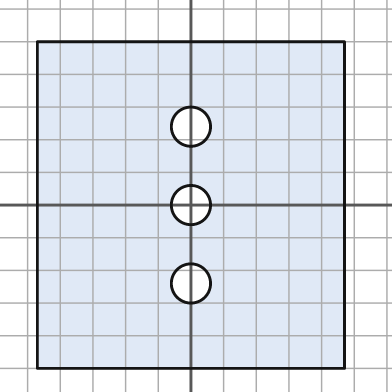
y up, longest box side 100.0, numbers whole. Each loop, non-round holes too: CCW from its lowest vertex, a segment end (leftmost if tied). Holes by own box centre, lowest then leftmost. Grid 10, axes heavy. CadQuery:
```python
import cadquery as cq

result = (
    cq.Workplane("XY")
    .moveTo(-47.0, -50.0)
    .lineTo(47.0, -50.0)
    .lineTo(47.0, 50.0)
    .lineTo(-47.0, 50.0)
    .close()
    .moveTo(0.0, -24.0)
    .circle(6.0)
    .moveTo(0.0, 0.0)
    .circle(6.0)
    .moveTo(0.0, 24.0)
    .circle(6.0)
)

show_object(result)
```